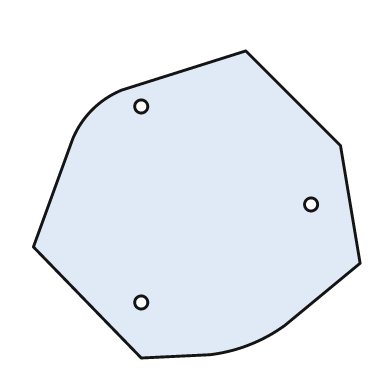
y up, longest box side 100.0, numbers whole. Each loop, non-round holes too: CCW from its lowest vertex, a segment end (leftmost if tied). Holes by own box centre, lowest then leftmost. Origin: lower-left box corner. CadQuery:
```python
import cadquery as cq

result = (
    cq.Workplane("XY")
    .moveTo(33.0, 0.0)
    .lineTo(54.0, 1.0)
    .threePointArc((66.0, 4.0), (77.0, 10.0))
    .lineTo(100.0, 29.0)
    .lineTo(94.0, 65.0)
    .lineTo(65.0, 94.0)
    .lineTo(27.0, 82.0)
    .threePointArc((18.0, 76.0), (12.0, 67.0))
    .lineTo(0.0, 34.0)
    .close()
    .moveTo(33.0, 17.0)
    .circle(2.0)
    .moveTo(85.0, 47.0)
    .circle(2.0)
    .moveTo(33.0, 77.0)
    .circle(2.0)
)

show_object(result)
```